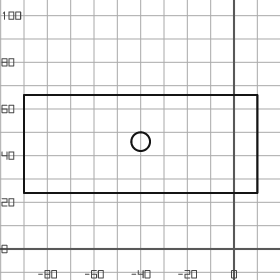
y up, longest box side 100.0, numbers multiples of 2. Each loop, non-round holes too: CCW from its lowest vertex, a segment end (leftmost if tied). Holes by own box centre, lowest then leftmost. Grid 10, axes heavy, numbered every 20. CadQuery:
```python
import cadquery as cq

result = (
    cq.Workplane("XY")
    .moveTo(-90.0, 24.0)
    .lineTo(10.0, 24.0)
    .lineTo(10.0, 66.0)
    .lineTo(-90.0, 66.0)
    .close()
    .moveTo(-40.0, 46.0)
    .circle(4.0)
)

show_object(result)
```